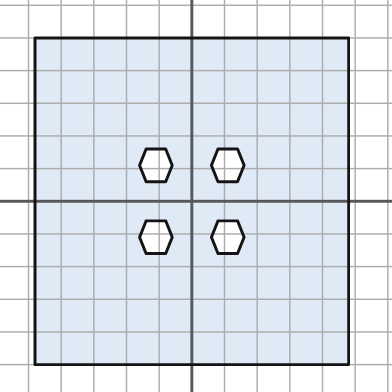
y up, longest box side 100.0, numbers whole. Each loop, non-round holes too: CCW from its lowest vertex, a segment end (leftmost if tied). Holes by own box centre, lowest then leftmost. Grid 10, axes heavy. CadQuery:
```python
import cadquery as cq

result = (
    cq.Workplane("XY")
    .moveTo(-48.0, -50.0)
    .lineTo(48.0, -50.0)
    .lineTo(48.0, 50.0)
    .lineTo(-48.0, 50.0)
    .close()
    .moveTo(-14.0, -16.0)
    .lineTo(-8.0, -16.0)
    .lineTo(-6.0, -11.0)
    .lineTo(-8.0, -6.0)
    .lineTo(-14.0, -6.0)
    .lineTo(-16.0, -11.0)
    .close()
    .moveTo(8.0, -16.0)
    .lineTo(14.0, -16.0)
    .lineTo(16.0, -11.0)
    .lineTo(14.0, -6.0)
    .lineTo(8.0, -6.0)
    .lineTo(6.0, -11.0)
    .close()
    .moveTo(-14.0, 6.0)
    .lineTo(-8.0, 6.0)
    .lineTo(-6.0, 11.0)
    .lineTo(-8.0, 16.0)
    .lineTo(-14.0, 16.0)
    .lineTo(-16.0, 11.0)
    .close()
    .moveTo(8.0, 6.0)
    .lineTo(14.0, 6.0)
    .lineTo(16.0, 11.0)
    .lineTo(14.0, 16.0)
    .lineTo(8.0, 16.0)
    .lineTo(6.0, 11.0)
    .close()
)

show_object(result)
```